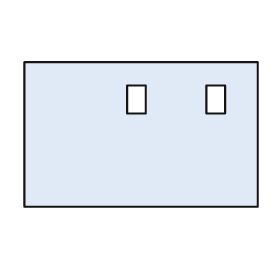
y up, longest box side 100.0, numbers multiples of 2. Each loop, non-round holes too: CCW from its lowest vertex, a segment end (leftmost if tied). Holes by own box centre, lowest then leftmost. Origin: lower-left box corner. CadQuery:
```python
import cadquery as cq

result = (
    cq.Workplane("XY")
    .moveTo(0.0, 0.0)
    .lineTo(100.0, 0.0)
    .lineTo(100.0, 62.0)
    .lineTo(0.0, 62.0)
    .close()
    .moveTo(44.0, 40.0)
    .lineTo(52.0, 40.0)
    .lineTo(52.0, 52.0)
    .lineTo(44.0, 52.0)
    .close()
    .moveTo(78.0, 40.0)
    .lineTo(86.0, 40.0)
    .lineTo(86.0, 52.0)
    .lineTo(78.0, 52.0)
    .close()
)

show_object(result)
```